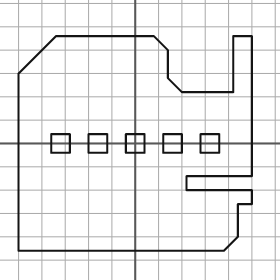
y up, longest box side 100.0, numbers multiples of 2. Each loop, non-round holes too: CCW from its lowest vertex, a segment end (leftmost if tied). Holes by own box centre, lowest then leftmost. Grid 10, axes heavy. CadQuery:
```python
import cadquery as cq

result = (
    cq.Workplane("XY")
    .moveTo(-50.0, -46.0)
    .lineTo(38.0, -46.0)
    .lineTo(44.0, -40.0)
    .lineTo(44.0, -26.0)
    .lineTo(50.0, -26.0)
    .lineTo(50.0, -20.0)
    .lineTo(22.0, -20.0)
    .lineTo(22.0, -14.0)
    .lineTo(50.0, -14.0)
    .lineTo(50.0, 46.0)
    .lineTo(42.0, 46.0)
    .lineTo(42.0, 22.0)
    .lineTo(20.0, 22.0)
    .lineTo(14.0, 28.0)
    .lineTo(14.0, 40.0)
    .lineTo(8.0, 46.0)
    .lineTo(-34.0, 46.0)
    .lineTo(-50.0, 30.0)
    .close()
    .moveTo(-36.0, -4.0)
    .lineTo(-28.0, -4.0)
    .lineTo(-28.0, 4.0)
    .lineTo(-36.0, 4.0)
    .close()
    .moveTo(-20.0, -4.0)
    .lineTo(-12.0, -4.0)
    .lineTo(-12.0, 4.0)
    .lineTo(-20.0, 4.0)
    .close()
    .moveTo(-4.0, -4.0)
    .lineTo(4.0, -4.0)
    .lineTo(4.0, 4.0)
    .lineTo(-4.0, 4.0)
    .close()
    .moveTo(12.0, -4.0)
    .lineTo(20.0, -4.0)
    .lineTo(20.0, 4.0)
    .lineTo(12.0, 4.0)
    .close()
    .moveTo(28.0, -4.0)
    .lineTo(36.0, -4.0)
    .lineTo(36.0, 4.0)
    .lineTo(28.0, 4.0)
    .close()
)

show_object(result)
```